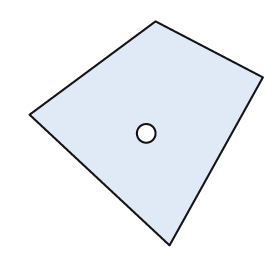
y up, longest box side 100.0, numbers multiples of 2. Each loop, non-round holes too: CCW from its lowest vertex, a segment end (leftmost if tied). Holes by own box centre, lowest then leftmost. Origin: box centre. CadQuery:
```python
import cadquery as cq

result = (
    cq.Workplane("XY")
    .moveTo(10.0, -48.0)
    .lineTo(50.0, 24.0)
    .lineTo(4.0, 48.0)
    .lineTo(-50.0, 8.0)
    .close()
    .moveTo(0.0, 0.0)
    .circle(4.0)
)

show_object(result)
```